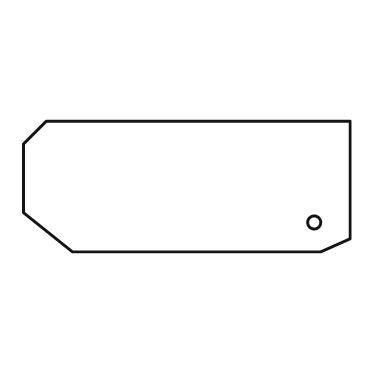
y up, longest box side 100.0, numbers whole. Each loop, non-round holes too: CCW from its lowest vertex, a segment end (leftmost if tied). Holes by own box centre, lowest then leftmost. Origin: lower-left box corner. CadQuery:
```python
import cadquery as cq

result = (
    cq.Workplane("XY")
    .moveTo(15.0, 0.0)
    .lineTo(91.0, 0.0)
    .lineTo(100.0, 4.0)
    .lineTo(100.0, 40.0)
    .lineTo(7.0, 40.0)
    .lineTo(0.0, 33.0)
    .lineTo(0.0, 12.0)
    .close()
    .moveTo(89.0, 9.0)
    .circle(2.0)
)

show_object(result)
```